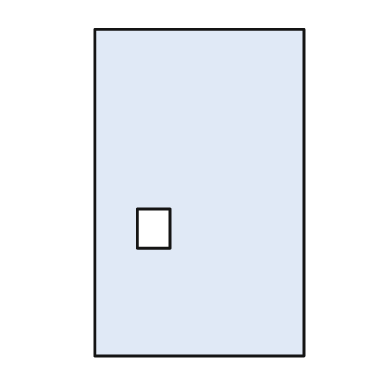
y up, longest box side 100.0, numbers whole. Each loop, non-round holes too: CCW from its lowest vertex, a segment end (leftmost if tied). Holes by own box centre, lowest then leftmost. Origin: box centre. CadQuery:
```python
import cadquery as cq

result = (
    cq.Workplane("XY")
    .moveTo(-32.0, -50.0)
    .lineTo(32.0, -50.0)
    .lineTo(32.0, 50.0)
    .lineTo(-32.0, 50.0)
    .close()
    .moveTo(-19.0, -17.0)
    .lineTo(-9.0, -17.0)
    .lineTo(-9.0, -5.0)
    .lineTo(-19.0, -5.0)
    .close()
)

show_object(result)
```